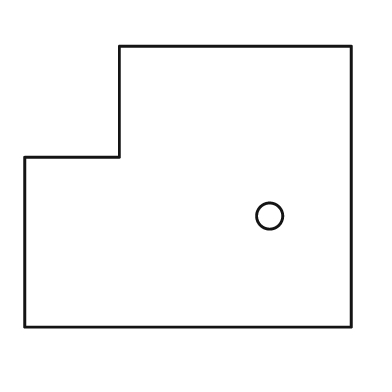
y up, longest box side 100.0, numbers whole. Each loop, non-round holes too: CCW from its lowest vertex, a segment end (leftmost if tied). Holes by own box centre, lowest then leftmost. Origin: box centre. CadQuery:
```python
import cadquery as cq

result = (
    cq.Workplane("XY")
    .moveTo(-50.0, -43.0)
    .lineTo(50.0, -43.0)
    .lineTo(50.0, 43.0)
    .lineTo(-21.0, 43.0)
    .lineTo(-21.0, 9.0)
    .lineTo(-50.0, 9.0)
    .close()
    .moveTo(25.0, -9.0)
    .circle(4.0)
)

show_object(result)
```